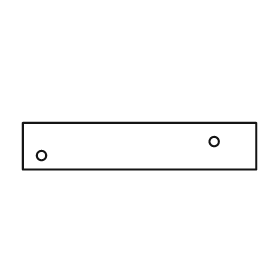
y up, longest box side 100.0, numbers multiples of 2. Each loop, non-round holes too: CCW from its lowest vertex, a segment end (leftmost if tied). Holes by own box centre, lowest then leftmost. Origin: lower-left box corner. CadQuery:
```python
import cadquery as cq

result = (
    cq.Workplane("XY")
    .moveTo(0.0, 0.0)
    .lineTo(100.0, 0.0)
    .lineTo(100.0, 20.0)
    .lineTo(0.0, 20.0)
    .close()
    .moveTo(8.0, 6.0)
    .circle(2.0)
    .moveTo(82.0, 12.0)
    .circle(2.0)
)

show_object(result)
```